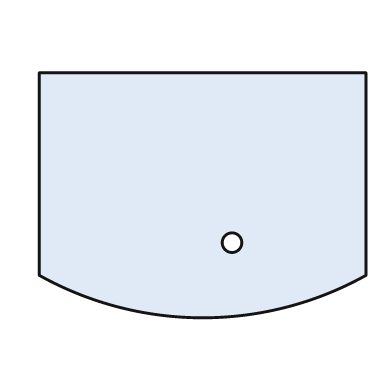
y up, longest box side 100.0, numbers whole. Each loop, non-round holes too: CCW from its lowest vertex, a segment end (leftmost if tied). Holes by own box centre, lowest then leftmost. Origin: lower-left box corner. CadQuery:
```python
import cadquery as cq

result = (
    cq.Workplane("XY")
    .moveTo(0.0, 13.0)
    .threePointArc((50.0, 0.0), (100.0, 13.0))
    .lineTo(100.0, 75.0)
    .lineTo(0.0, 75.0)
    .close()
    .moveTo(59.0, 23.0)
    .circle(3.0)
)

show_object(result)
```